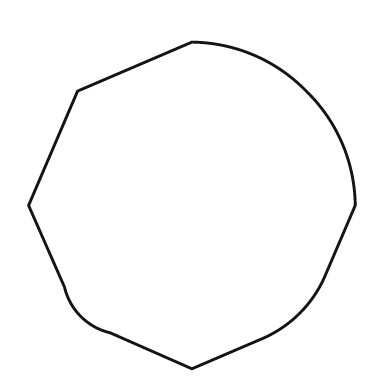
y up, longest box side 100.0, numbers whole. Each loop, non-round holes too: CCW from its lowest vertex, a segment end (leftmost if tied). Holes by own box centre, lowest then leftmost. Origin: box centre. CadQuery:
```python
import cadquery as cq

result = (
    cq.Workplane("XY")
    .moveTo(0.0, -50.0)
    .lineTo(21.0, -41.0)
    .threePointArc((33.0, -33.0), (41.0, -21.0))
    .lineTo(50.0, 0.0)
    .threePointArc((46.0, 19.0), (35.0, 35.0))
    .threePointArc((19.0, 46.0), (0.0, 50.0))
    .lineTo(-35.0, 35.0)
    .lineTo(-50.0, 0.0)
    .lineTo(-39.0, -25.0)
    .threePointArc((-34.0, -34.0), (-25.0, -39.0))
    .close()
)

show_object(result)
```